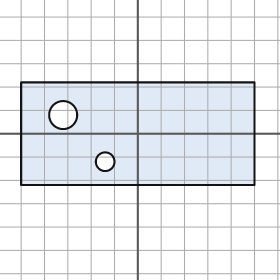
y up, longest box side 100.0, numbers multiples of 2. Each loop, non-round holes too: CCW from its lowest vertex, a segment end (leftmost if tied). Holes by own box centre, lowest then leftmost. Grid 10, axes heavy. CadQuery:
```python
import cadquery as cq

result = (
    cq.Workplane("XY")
    .moveTo(-50.0, -22.0)
    .lineTo(50.0, -22.0)
    .lineTo(50.0, 22.0)
    .lineTo(-50.0, 22.0)
    .close()
    .moveTo(-14.0, -12.0)
    .circle(4.0)
    .moveTo(-32.0, 8.0)
    .circle(6.0)
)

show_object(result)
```